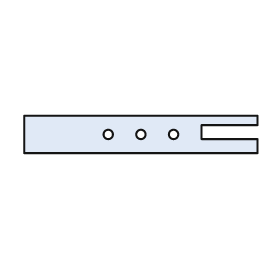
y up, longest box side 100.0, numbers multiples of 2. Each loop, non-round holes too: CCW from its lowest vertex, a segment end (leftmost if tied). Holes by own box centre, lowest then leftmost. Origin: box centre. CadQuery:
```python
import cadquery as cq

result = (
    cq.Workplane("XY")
    .moveTo(-50.0, -8.0)
    .lineTo(50.0, -8.0)
    .lineTo(50.0, -2.0)
    .lineTo(26.0, -2.0)
    .lineTo(26.0, 4.0)
    .lineTo(50.0, 4.0)
    .lineTo(50.0, 8.0)
    .lineTo(-50.0, 8.0)
    .close()
    .moveTo(-14.0, 0.0)
    .circle(2.0)
    .moveTo(0.0, 0.0)
    .circle(2.0)
    .moveTo(14.0, 0.0)
    .circle(2.0)
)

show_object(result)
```